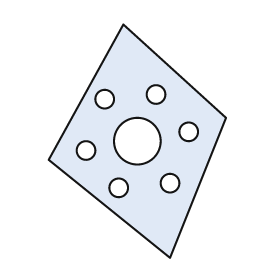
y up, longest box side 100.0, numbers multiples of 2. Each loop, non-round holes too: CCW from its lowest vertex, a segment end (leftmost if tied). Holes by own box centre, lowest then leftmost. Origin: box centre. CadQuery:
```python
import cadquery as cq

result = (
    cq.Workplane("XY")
    .moveTo(14.0, -50.0)
    .lineTo(38.0, 10.0)
    .lineTo(-6.0, 50.0)
    .lineTo(-38.0, -8.0)
    .close()
    .moveTo(-8.0, -20.0)
    .circle(4.0)
    .moveTo(14.0, -18.0)
    .circle(4.0)
    .moveTo(-22.0, -4.0)
    .circle(4.0)
    .moveTo(0.0, 0.0)
    .circle(10.0)
    .moveTo(22.0, 4.0)
    .circle(4.0)
    .moveTo(-14.0, 18.0)
    .circle(4.0)
    .moveTo(8.0, 20.0)
    .circle(4.0)
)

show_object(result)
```